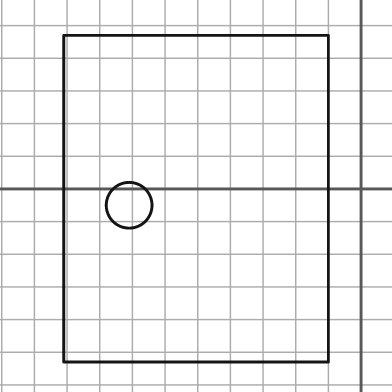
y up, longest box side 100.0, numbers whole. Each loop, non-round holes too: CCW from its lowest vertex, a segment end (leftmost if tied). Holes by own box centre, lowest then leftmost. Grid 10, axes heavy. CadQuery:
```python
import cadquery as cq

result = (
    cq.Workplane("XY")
    .moveTo(-91.0, -53.0)
    .lineTo(-10.0, -53.0)
    .lineTo(-10.0, 47.0)
    .lineTo(-91.0, 47.0)
    .close()
    .moveTo(-71.0, -5.0)
    .circle(7.0)
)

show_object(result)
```